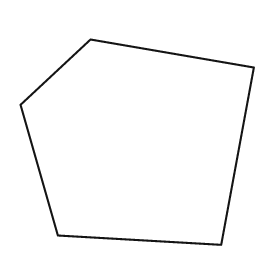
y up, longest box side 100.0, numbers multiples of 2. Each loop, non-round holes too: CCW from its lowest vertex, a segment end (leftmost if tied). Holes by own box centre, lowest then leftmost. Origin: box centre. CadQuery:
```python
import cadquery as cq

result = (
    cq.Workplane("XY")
    .moveTo(36.0, -44.0)
    .lineTo(50.0, 32.0)
    .lineTo(-20.0, 44.0)
    .lineTo(-50.0, 16.0)
    .lineTo(-34.0, -40.0)
    .close()
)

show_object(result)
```